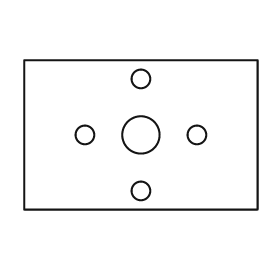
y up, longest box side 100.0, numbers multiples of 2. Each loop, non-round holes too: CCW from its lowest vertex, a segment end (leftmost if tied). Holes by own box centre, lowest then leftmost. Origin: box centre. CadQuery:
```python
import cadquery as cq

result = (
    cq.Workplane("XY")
    .moveTo(-50.0, -32.0)
    .lineTo(50.0, -32.0)
    .lineTo(50.0, 32.0)
    .lineTo(-50.0, 32.0)
    .close()
    .moveTo(0.0, -24.0)
    .circle(4.0)
    .moveTo(-24.0, 0.0)
    .circle(4.0)
    .moveTo(0.0, 0.0)
    .circle(8.0)
    .moveTo(24.0, 0.0)
    .circle(4.0)
    .moveTo(0.0, 24.0)
    .circle(4.0)
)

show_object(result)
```